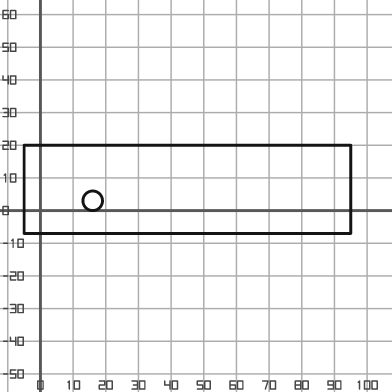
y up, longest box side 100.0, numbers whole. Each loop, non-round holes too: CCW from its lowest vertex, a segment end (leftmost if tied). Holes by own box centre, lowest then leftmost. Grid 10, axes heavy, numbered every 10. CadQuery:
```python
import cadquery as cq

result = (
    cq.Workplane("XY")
    .moveTo(-5.0, -7.0)
    .lineTo(95.0, -7.0)
    .lineTo(95.0, 20.0)
    .lineTo(-5.0, 20.0)
    .close()
    .moveTo(16.0, 3.0)
    .circle(3.0)
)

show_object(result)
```